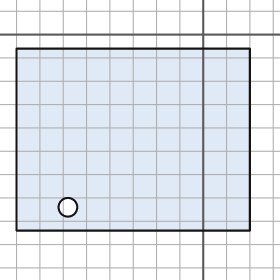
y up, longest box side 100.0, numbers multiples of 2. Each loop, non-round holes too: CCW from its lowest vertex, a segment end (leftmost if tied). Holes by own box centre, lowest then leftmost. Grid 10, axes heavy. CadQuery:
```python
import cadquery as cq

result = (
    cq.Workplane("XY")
    .moveTo(-80.0, -84.0)
    .lineTo(20.0, -84.0)
    .lineTo(20.0, -6.0)
    .lineTo(-80.0, -6.0)
    .close()
    .moveTo(-58.0, -74.0)
    .circle(4.0)
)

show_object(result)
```